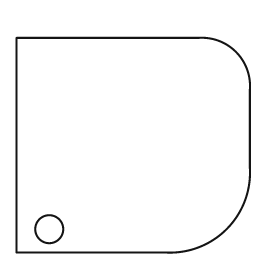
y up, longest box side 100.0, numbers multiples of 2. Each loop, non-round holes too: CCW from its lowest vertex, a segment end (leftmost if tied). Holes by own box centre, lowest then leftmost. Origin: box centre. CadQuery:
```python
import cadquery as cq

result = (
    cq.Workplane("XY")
    .moveTo(-50.0, -46.0)
    .lineTo(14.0, -46.0)
    .threePointArc((40.0, -36.0), (50.0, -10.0))
    .lineTo(50.0, 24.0)
    .threePointArc((44.0, 40.0), (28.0, 46.0))
    .lineTo(-50.0, 46.0)
    .close()
    .moveTo(-36.0, -36.0)
    .circle(6.0)
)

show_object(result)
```